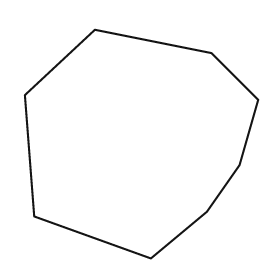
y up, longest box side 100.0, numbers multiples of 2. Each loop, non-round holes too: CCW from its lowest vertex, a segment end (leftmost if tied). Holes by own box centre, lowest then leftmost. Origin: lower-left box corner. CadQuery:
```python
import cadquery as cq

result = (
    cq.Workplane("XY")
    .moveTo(54.0, 0.0)
    .lineTo(78.0, 20.0)
    .lineTo(92.0, 40.0)
    .lineTo(100.0, 68.0)
    .lineTo(80.0, 88.0)
    .lineTo(30.0, 98.0)
    .lineTo(0.0, 70.0)
    .lineTo(4.0, 18.0)
    .close()
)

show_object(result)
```